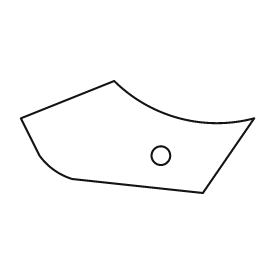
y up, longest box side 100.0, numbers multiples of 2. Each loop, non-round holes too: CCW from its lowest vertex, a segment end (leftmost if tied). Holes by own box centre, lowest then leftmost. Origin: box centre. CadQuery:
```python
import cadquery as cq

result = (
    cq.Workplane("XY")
    .moveTo(28.0, -24.0)
    .lineTo(50.0, 8.0)
    .threePointArc((18.0, 8.0), (-10.0, 24.0))
    .lineTo(-50.0, 8.0)
    .lineTo(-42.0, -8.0)
    .threePointArc((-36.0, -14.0), (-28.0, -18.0))
    .close()
    .moveTo(10.0, -8.0)
    .circle(4.0)
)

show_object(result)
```